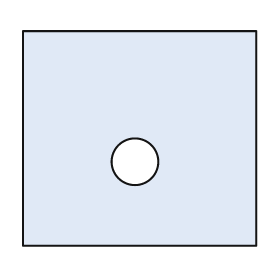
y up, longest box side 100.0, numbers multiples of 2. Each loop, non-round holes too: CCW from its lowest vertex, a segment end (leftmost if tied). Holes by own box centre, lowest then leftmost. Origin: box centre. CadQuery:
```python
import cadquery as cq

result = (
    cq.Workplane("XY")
    .moveTo(-50.0, -46.0)
    .lineTo(50.0, -46.0)
    .lineTo(50.0, 46.0)
    .lineTo(-50.0, 46.0)
    .close()
    .moveTo(-2.0, -10.0)
    .circle(10.0)
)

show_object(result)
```